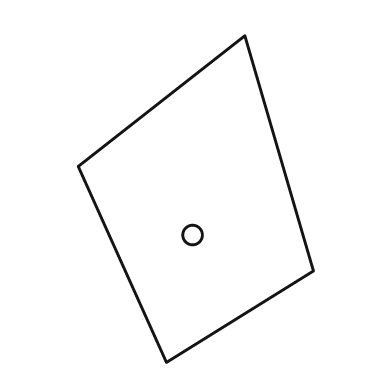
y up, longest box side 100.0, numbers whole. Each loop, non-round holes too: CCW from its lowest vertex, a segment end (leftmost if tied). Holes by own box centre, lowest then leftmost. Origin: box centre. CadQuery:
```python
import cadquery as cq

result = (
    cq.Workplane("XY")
    .moveTo(-9.0, -50.0)
    .lineTo(36.0, -22.0)
    .lineTo(15.0, 50.0)
    .lineTo(-36.0, 10.0)
    .close()
    .moveTo(-1.0, -11.0)
    .circle(3.0)
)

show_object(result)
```